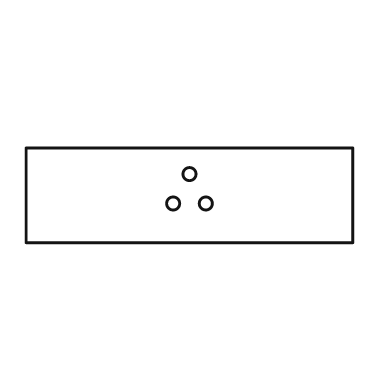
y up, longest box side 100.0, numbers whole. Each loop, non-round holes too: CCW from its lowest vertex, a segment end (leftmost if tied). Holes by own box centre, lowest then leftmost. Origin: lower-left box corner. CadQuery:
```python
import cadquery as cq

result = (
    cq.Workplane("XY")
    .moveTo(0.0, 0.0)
    .lineTo(100.0, 0.0)
    .lineTo(100.0, 29.0)
    .lineTo(0.0, 29.0)
    .close()
    .moveTo(45.0, 12.0)
    .circle(2.0)
    .moveTo(55.0, 12.0)
    .circle(2.0)
    .moveTo(50.0, 21.0)
    .circle(2.0)
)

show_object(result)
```